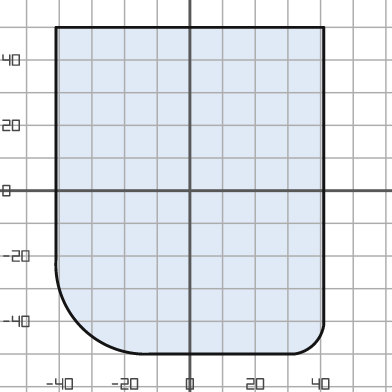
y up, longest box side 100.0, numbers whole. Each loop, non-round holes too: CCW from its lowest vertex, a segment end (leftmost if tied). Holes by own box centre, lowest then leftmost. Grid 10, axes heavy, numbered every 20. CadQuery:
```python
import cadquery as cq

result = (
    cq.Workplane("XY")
    .moveTo(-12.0, -50.0)
    .lineTo(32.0, -50.0)
    .threePointArc((38.0, -47.0), (41.0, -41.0))
    .lineTo(41.0, 50.0)
    .lineTo(-41.0, 50.0)
    .lineTo(-41.0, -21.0)
    .threePointArc((-33.0, -42.0), (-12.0, -50.0))
    .close()
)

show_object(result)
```